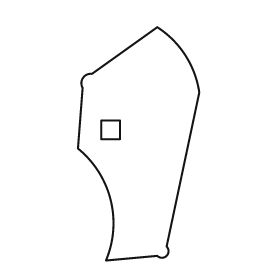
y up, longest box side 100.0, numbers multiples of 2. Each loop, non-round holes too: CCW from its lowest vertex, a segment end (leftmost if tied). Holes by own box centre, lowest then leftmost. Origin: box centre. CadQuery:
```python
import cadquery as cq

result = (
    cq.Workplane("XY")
    .moveTo(-14.0, -50.0)
    .lineTo(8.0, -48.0)
    .threePointArc((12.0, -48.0), (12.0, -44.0))
    .lineTo(26.0, 22.0)
    .threePointArc((20.0, 38.0), (8.0, 50.0))
    .lineTo(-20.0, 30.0)
    .threePointArc((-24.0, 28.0), (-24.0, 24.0))
    .lineTo(-26.0, -2.0)
    .threePointArc((-12.0, -24.0), (-14.0, -50.0))
    .close()
    .moveTo(-16.0, 2.0)
    .lineTo(-8.0, 2.0)
    .lineTo(-8.0, 10.0)
    .lineTo(-16.0, 10.0)
    .close()
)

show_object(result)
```